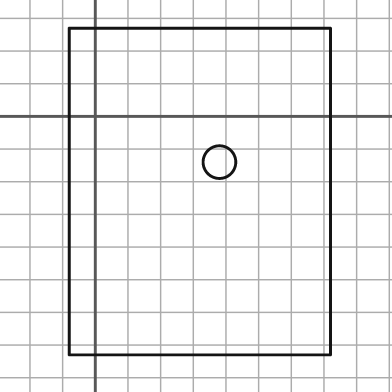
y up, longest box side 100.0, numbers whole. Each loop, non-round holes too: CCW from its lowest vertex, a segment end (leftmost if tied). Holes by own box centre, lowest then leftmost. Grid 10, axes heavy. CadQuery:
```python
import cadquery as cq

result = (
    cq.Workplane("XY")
    .moveTo(-8.0, -73.0)
    .lineTo(72.0, -73.0)
    .lineTo(72.0, 27.0)
    .lineTo(-8.0, 27.0)
    .close()
    .moveTo(38.0, -14.0)
    .circle(5.0)
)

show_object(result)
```